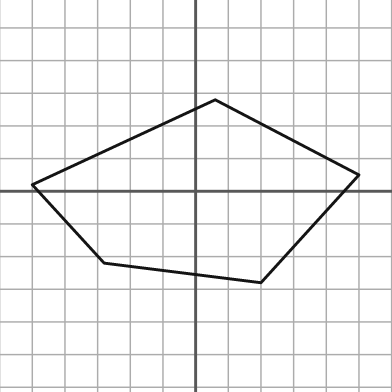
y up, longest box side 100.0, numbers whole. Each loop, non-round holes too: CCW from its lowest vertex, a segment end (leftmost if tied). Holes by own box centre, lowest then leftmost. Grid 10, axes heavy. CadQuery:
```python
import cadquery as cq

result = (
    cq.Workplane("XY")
    .moveTo(20.0, -28.0)
    .lineTo(50.0, 5.0)
    .lineTo(6.0, 28.0)
    .lineTo(-50.0, 2.0)
    .lineTo(-28.0, -22.0)
    .close()
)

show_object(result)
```